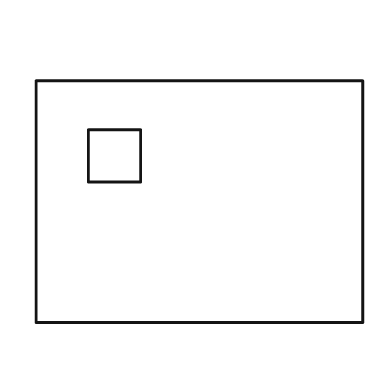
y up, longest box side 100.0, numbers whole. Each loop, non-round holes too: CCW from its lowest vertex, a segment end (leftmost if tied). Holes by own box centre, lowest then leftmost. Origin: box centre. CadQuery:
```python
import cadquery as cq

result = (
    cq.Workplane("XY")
    .moveTo(-50.0, -37.0)
    .lineTo(50.0, -37.0)
    .lineTo(50.0, 37.0)
    .lineTo(-50.0, 37.0)
    .close()
    .moveTo(-34.0, 6.0)
    .lineTo(-18.0, 6.0)
    .lineTo(-18.0, 22.0)
    .lineTo(-34.0, 22.0)
    .close()
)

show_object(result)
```